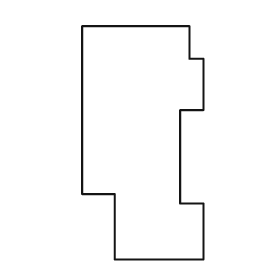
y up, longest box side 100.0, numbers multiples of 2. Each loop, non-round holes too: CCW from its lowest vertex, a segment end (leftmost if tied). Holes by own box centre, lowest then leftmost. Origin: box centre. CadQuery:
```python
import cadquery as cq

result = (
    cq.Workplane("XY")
    .moveTo(-12.0, -50.0)
    .lineTo(26.0, -50.0)
    .lineTo(26.0, -26.0)
    .lineTo(16.0, -26.0)
    .lineTo(16.0, 14.0)
    .lineTo(26.0, 14.0)
    .lineTo(26.0, 36.0)
    .lineTo(20.0, 36.0)
    .lineTo(20.0, 50.0)
    .lineTo(-26.0, 50.0)
    .lineTo(-26.0, -22.0)
    .lineTo(-12.0, -22.0)
    .close()
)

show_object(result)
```